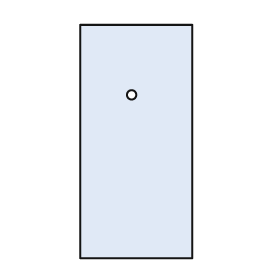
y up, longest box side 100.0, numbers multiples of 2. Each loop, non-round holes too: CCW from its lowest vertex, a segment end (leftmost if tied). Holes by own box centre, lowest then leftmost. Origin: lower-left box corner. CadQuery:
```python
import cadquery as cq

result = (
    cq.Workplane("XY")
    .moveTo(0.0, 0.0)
    .lineTo(48.0, 0.0)
    .lineTo(48.0, 100.0)
    .lineTo(0.0, 100.0)
    .close()
    .moveTo(22.0, 70.0)
    .circle(2.0)
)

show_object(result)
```